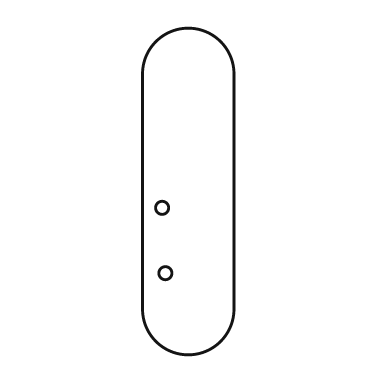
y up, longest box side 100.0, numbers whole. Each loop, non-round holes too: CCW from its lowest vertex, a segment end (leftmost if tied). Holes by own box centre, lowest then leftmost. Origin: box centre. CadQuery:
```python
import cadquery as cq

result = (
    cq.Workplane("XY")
    .moveTo(-14.0, -36.0)
    .threePointArc((0.0, -50.0), (14.0, -36.0))
    .lineTo(14.0, 36.0)
    .threePointArc((0.0, 50.0), (-14.0, 36.0))
    .close()
    .moveTo(-7.0, -25.0)
    .circle(2.0)
    .moveTo(-8.0, -5.0)
    .circle(2.0)
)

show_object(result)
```